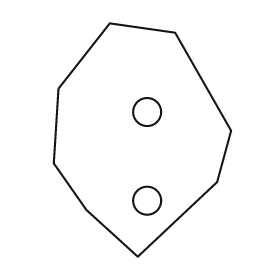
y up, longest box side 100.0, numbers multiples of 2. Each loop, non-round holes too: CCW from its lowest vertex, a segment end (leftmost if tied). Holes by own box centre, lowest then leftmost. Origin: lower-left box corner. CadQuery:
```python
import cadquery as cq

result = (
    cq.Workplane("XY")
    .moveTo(36.0, 0.0)
    .lineTo(70.0, 32.0)
    .lineTo(76.0, 54.0)
    .lineTo(52.0, 96.0)
    .lineTo(24.0, 100.0)
    .lineTo(2.0, 72.0)
    .lineTo(0.0, 40.0)
    .lineTo(14.0, 20.0)
    .close()
    .moveTo(40.0, 24.0)
    .circle(6.0)
    .moveTo(40.0, 62.0)
    .circle(6.0)
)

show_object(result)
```